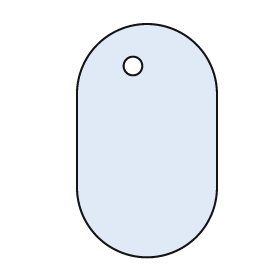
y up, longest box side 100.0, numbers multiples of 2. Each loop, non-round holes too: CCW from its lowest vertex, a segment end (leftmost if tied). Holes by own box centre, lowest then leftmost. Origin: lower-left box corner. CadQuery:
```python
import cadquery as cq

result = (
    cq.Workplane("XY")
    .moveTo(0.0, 30.0)
    .threePointArc((30.0, 0.0), (60.0, 30.0))
    .lineTo(60.0, 70.0)
    .threePointArc((30.0, 100.0), (0.0, 70.0))
    .close()
    .moveTo(24.0, 82.0)
    .circle(4.0)
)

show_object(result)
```